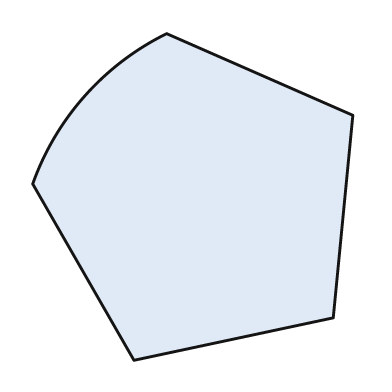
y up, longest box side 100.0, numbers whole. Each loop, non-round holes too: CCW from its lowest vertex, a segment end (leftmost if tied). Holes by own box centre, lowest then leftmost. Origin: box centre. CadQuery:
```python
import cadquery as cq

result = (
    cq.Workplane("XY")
    .moveTo(-18.0, -50.0)
    .lineTo(43.0, -37.0)
    .lineTo(49.0, 25.0)
    .lineTo(-8.0, 50.0)
    .threePointArc((-33.0, 31.0), (-49.0, 4.0))
    .close()
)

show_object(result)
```